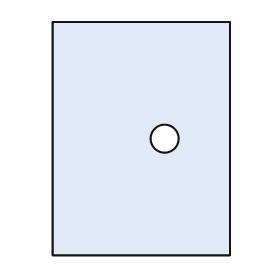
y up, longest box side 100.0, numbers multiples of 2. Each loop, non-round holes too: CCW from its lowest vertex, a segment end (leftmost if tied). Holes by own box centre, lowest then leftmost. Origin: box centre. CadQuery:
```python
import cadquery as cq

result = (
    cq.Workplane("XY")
    .moveTo(-38.0, -50.0)
    .lineTo(38.0, -50.0)
    .lineTo(38.0, 50.0)
    .lineTo(-38.0, 50.0)
    .close()
    .moveTo(10.0, 0.0)
    .circle(6.0)
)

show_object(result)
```